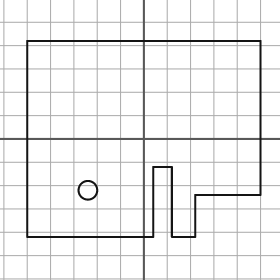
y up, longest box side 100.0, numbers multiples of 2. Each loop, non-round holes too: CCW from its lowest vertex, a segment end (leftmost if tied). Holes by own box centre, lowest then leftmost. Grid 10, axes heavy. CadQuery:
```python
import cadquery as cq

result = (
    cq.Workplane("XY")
    .moveTo(-50.0, -42.0)
    .lineTo(4.0, -42.0)
    .lineTo(4.0, -12.0)
    .lineTo(12.0, -12.0)
    .lineTo(12.0, -42.0)
    .lineTo(22.0, -42.0)
    .lineTo(22.0, -24.0)
    .lineTo(50.0, -24.0)
    .lineTo(50.0, 42.0)
    .lineTo(-50.0, 42.0)
    .close()
    .moveTo(-24.0, -22.0)
    .circle(4.0)
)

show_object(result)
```